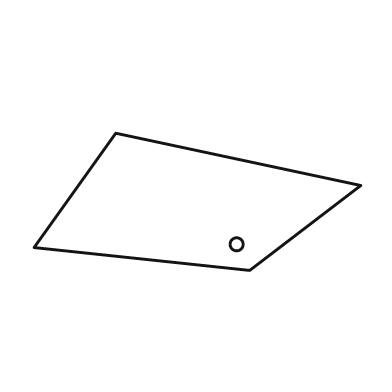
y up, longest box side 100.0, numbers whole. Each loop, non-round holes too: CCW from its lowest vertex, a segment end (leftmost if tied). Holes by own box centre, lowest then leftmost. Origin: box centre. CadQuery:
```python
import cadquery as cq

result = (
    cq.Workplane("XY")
    .moveTo(16.0, -21.0)
    .lineTo(50.0, 5.0)
    .lineTo(-25.0, 21.0)
    .lineTo(-50.0, -14.0)
    .close()
    .moveTo(12.0, -13.0)
    .circle(2.0)
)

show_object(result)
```